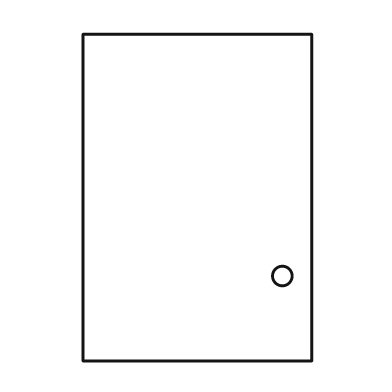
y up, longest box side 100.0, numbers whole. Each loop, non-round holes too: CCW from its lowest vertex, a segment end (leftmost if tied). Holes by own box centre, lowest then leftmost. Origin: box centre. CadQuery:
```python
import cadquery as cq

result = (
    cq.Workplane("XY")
    .moveTo(-35.0, -50.0)
    .lineTo(35.0, -50.0)
    .lineTo(35.0, 50.0)
    .lineTo(-35.0, 50.0)
    .close()
    .moveTo(26.0, -24.0)
    .circle(3.0)
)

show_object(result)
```